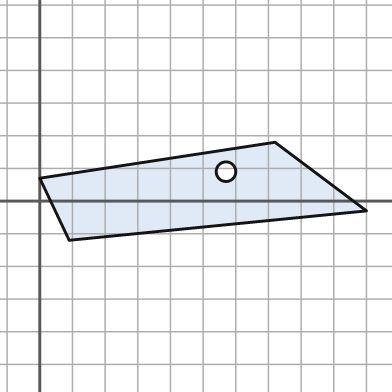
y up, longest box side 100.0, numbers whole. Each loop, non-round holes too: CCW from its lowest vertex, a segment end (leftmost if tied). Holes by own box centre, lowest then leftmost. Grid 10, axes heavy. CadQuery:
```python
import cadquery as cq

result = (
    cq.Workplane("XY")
    .moveTo(9.0, -12.0)
    .lineTo(100.0, -3.0)
    .lineTo(72.0, 18.0)
    .lineTo(0.0, 7.0)
    .close()
    .moveTo(57.0, 9.0)
    .circle(3.0)
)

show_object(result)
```